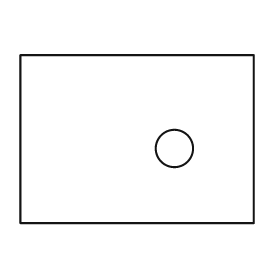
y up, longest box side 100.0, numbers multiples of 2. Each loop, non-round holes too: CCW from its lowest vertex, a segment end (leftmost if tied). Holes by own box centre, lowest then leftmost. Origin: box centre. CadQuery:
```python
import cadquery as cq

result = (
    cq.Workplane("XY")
    .moveTo(-50.0, -36.0)
    .lineTo(50.0, -36.0)
    .lineTo(50.0, 36.0)
    .lineTo(-50.0, 36.0)
    .close()
    .moveTo(16.0, -4.0)
    .circle(8.0)
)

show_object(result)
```